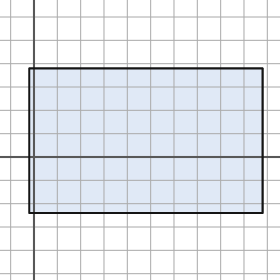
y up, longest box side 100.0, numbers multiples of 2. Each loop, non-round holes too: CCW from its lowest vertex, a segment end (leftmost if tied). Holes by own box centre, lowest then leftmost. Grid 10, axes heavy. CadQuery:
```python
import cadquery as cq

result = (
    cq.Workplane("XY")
    .moveTo(-2.0, -24.0)
    .lineTo(98.0, -24.0)
    .lineTo(98.0, 38.0)
    .lineTo(-2.0, 38.0)
    .close()
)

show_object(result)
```